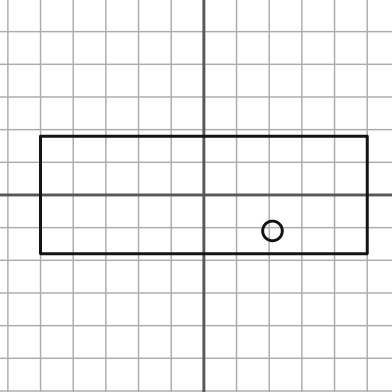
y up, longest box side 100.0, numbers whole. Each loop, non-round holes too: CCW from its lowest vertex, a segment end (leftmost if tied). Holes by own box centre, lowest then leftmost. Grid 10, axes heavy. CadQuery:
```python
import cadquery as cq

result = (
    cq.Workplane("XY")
    .moveTo(-50.0, -18.0)
    .lineTo(50.0, -18.0)
    .lineTo(50.0, 18.0)
    .lineTo(-50.0, 18.0)
    .close()
    .moveTo(21.0, -11.0)
    .circle(3.0)
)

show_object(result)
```